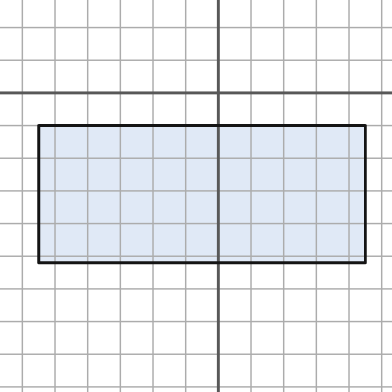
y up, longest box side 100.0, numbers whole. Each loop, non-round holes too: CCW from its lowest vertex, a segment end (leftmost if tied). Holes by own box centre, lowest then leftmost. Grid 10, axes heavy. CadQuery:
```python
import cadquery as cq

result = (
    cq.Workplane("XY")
    .moveTo(-55.0, -52.0)
    .lineTo(45.0, -52.0)
    .lineTo(45.0, -10.0)
    .lineTo(-55.0, -10.0)
    .close()
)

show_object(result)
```